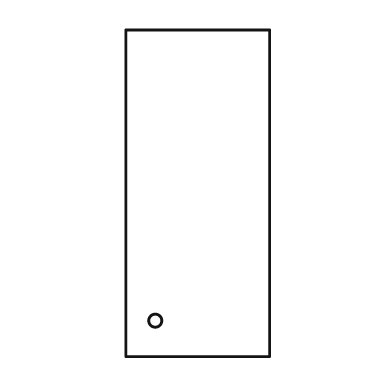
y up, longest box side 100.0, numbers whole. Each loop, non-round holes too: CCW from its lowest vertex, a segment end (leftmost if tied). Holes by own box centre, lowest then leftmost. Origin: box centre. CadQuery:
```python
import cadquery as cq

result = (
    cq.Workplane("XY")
    .moveTo(-22.0, -50.0)
    .lineTo(22.0, -50.0)
    .lineTo(22.0, 50.0)
    .lineTo(-22.0, 50.0)
    .close()
    .moveTo(-13.0, -39.0)
    .circle(2.0)
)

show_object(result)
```